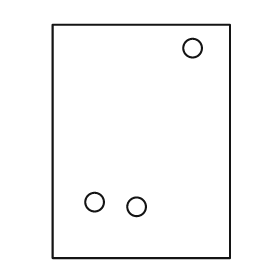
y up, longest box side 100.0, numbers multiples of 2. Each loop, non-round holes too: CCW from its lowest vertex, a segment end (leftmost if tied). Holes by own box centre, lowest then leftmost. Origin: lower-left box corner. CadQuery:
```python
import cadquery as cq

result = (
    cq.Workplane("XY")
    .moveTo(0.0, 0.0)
    .lineTo(76.0, 0.0)
    .lineTo(76.0, 100.0)
    .lineTo(0.0, 100.0)
    .close()
    .moveTo(36.0, 22.0)
    .circle(4.0)
    .moveTo(18.0, 24.0)
    .circle(4.0)
    .moveTo(60.0, 90.0)
    .circle(4.0)
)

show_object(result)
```